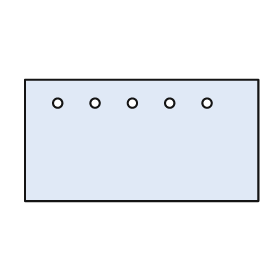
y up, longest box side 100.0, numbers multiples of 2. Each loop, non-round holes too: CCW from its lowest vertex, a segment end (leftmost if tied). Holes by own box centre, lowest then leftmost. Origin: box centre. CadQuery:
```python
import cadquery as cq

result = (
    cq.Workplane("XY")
    .moveTo(-50.0, -26.0)
    .lineTo(50.0, -26.0)
    .lineTo(50.0, 26.0)
    .lineTo(-50.0, 26.0)
    .close()
    .moveTo(-36.0, 16.0)
    .circle(2.0)
    .moveTo(-20.0, 16.0)
    .circle(2.0)
    .moveTo(-4.0, 16.0)
    .circle(2.0)
    .moveTo(12.0, 16.0)
    .circle(2.0)
    .moveTo(28.0, 16.0)
    .circle(2.0)
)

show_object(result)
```